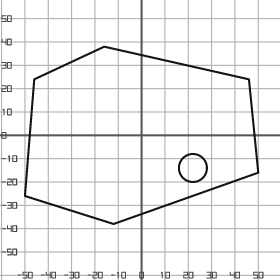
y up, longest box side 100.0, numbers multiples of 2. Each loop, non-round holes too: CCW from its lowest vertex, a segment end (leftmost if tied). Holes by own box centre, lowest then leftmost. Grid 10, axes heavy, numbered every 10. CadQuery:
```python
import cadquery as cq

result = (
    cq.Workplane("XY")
    .moveTo(-12.0, -38.0)
    .lineTo(50.0, -16.0)
    .lineTo(46.0, 24.0)
    .lineTo(-16.0, 38.0)
    .lineTo(-46.0, 24.0)
    .lineTo(-50.0, -26.0)
    .close()
    .moveTo(22.0, -14.0)
    .circle(6.0)
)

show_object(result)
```